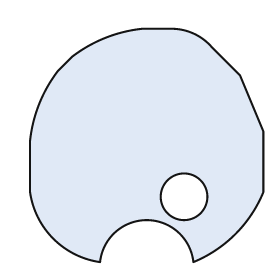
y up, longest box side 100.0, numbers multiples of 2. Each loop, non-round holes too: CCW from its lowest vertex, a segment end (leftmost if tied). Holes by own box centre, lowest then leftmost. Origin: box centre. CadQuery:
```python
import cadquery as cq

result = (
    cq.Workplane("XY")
    .moveTo(-20.0, -50.0)
    .threePointArc((0.0, -32.0), (20.0, -50.0))
    .threePointArc((38.0, -38.0), (50.0, -20.0))
    .lineTo(50.0, 6.0)
    .lineTo(40.0, 30.0)
    .lineTo(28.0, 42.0)
    .threePointArc((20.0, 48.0), (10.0, 50.0))
    .lineTo(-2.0, 50.0)
    .threePointArc((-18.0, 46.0), (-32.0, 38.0))
    .lineTo(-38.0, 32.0)
    .threePointArc((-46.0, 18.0), (-50.0, 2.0))
    .lineTo(-50.0, -20.0)
    .threePointArc((-40.0, -40.0), (-20.0, -50.0))
    .close()
    .moveTo(16.0, -22.0)
    .circle(10.0)
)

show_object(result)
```